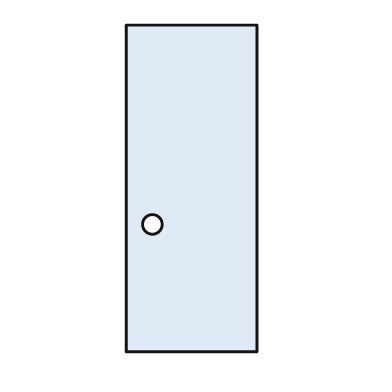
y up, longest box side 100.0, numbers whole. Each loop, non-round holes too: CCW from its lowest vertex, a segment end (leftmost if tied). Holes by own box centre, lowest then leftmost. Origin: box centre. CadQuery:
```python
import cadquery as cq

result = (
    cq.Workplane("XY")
    .moveTo(-20.0, -50.0)
    .lineTo(20.0, -50.0)
    .lineTo(20.0, 50.0)
    .lineTo(-20.0, 50.0)
    .close()
    .moveTo(-12.0, -11.0)
    .circle(3.0)
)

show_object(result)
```